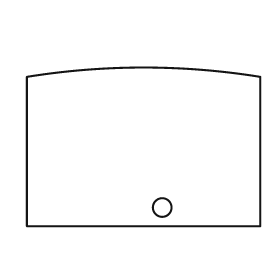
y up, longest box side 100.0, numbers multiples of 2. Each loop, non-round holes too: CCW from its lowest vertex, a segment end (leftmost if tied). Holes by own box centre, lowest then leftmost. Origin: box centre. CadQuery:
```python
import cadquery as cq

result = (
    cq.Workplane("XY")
    .moveTo(-50.0, -34.0)
    .lineTo(50.0, -34.0)
    .lineTo(50.0, 30.0)
    .threePointArc((0.0, 34.0), (-50.0, 30.0))
    .close()
    .moveTo(8.0, -26.0)
    .circle(4.0)
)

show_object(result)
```